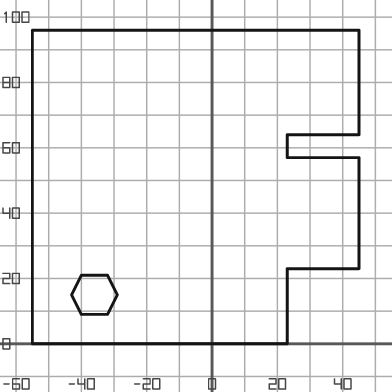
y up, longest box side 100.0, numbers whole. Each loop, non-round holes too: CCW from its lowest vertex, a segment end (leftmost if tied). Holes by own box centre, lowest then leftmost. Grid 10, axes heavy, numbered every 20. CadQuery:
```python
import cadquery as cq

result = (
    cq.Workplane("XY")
    .moveTo(-55.0, 0.0)
    .lineTo(23.0, 0.0)
    .lineTo(23.0, 23.0)
    .lineTo(45.0, 23.0)
    .lineTo(45.0, 57.0)
    .lineTo(23.0, 57.0)
    .lineTo(23.0, 64.0)
    .lineTo(45.0, 64.0)
    .lineTo(45.0, 96.0)
    .lineTo(-55.0, 96.0)
    .close()
    .moveTo(-40.0, 9.0)
    .lineTo(-32.0, 9.0)
    .lineTo(-29.0, 15.0)
    .lineTo(-32.0, 21.0)
    .lineTo(-40.0, 21.0)
    .lineTo(-43.0, 15.0)
    .close()
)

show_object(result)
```